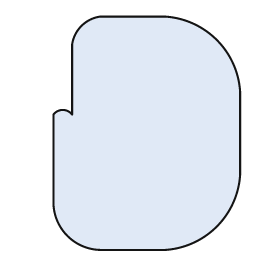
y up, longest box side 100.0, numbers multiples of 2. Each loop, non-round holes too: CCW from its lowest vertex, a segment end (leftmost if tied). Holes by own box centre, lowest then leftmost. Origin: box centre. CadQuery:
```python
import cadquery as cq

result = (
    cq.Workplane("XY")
    .moveTo(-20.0, -50.0)
    .lineTo(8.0, -50.0)
    .threePointArc((30.0, -40.0), (40.0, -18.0))
    .lineTo(40.0, 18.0)
    .threePointArc((30.0, 40.0), (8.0, 50.0))
    .lineTo(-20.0, 50.0)
    .threePointArc((-28.0, 46.0), (-32.0, 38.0))
    .lineTo(-32.0, 8.0)
    .threePointArc((-36.0, 10.0), (-40.0, 8.0))
    .lineTo(-40.0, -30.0)
    .threePointArc((-34.0, -44.0), (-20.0, -50.0))
    .close()
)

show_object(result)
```